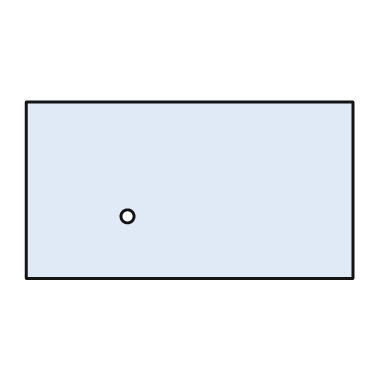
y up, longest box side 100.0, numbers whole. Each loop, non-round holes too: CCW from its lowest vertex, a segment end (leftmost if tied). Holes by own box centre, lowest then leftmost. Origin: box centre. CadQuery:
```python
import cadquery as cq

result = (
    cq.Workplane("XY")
    .moveTo(-50.0, -27.0)
    .lineTo(50.0, -27.0)
    .lineTo(50.0, 27.0)
    .lineTo(-50.0, 27.0)
    .close()
    .moveTo(-19.0, -8.0)
    .circle(2.0)
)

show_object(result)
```